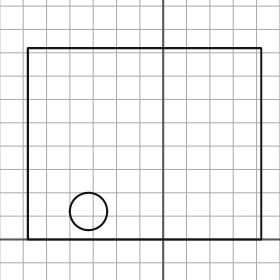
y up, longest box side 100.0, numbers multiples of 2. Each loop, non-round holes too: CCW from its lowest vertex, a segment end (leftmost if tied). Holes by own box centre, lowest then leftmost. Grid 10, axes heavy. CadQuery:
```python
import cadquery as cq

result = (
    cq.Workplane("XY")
    .moveTo(-58.0, 0.0)
    .lineTo(42.0, 0.0)
    .lineTo(42.0, 82.0)
    .lineTo(-58.0, 82.0)
    .close()
    .moveTo(-32.0, 12.0)
    .circle(8.0)
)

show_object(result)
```